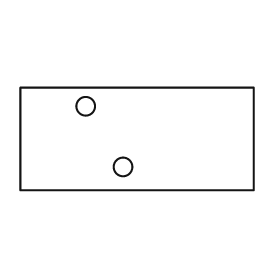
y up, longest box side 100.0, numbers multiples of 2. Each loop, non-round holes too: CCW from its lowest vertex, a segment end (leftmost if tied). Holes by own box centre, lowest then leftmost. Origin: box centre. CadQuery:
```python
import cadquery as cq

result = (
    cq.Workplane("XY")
    .moveTo(-50.0, -22.0)
    .lineTo(50.0, -22.0)
    .lineTo(50.0, 22.0)
    .lineTo(-50.0, 22.0)
    .close()
    .moveTo(-6.0, -12.0)
    .circle(4.0)
    .moveTo(-22.0, 14.0)
    .circle(4.0)
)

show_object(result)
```